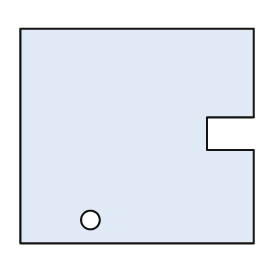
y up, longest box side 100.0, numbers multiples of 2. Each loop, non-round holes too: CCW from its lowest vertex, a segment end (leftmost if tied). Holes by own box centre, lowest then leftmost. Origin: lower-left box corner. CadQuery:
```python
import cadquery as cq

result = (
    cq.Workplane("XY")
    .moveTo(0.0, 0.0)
    .lineTo(100.0, 0.0)
    .lineTo(100.0, 40.0)
    .lineTo(80.0, 40.0)
    .lineTo(80.0, 54.0)
    .lineTo(100.0, 54.0)
    .lineTo(100.0, 92.0)
    .lineTo(0.0, 92.0)
    .close()
    .moveTo(30.0, 10.0)
    .circle(4.0)
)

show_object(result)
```